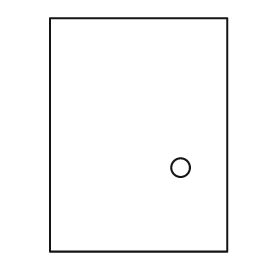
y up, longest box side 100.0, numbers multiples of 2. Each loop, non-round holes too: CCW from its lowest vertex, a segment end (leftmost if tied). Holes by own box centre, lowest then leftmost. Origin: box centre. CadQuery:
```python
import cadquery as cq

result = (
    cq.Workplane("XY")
    .moveTo(-38.0, -50.0)
    .lineTo(38.0, -50.0)
    .lineTo(38.0, 50.0)
    .lineTo(-38.0, 50.0)
    .close()
    .moveTo(18.0, -14.0)
    .circle(4.0)
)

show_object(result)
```